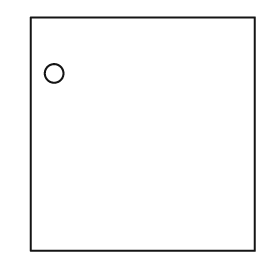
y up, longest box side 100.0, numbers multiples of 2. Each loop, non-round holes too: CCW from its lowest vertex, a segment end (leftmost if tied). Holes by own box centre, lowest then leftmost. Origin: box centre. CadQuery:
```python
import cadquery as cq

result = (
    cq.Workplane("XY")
    .moveTo(-48.0, -50.0)
    .lineTo(48.0, -50.0)
    .lineTo(48.0, 50.0)
    .lineTo(-48.0, 50.0)
    .close()
    .moveTo(-38.0, 26.0)
    .circle(4.0)
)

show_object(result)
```